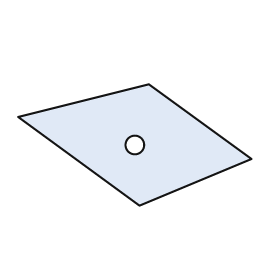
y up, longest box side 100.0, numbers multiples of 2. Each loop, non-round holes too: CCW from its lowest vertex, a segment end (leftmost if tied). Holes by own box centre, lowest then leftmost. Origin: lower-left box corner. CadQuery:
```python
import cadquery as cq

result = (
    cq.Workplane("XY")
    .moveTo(52.0, 0.0)
    .lineTo(100.0, 20.0)
    .lineTo(56.0, 52.0)
    .lineTo(0.0, 38.0)
    .close()
    .moveTo(50.0, 26.0)
    .circle(4.0)
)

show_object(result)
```